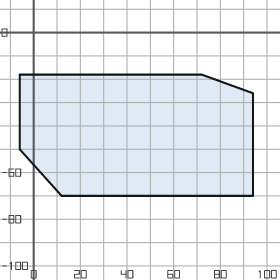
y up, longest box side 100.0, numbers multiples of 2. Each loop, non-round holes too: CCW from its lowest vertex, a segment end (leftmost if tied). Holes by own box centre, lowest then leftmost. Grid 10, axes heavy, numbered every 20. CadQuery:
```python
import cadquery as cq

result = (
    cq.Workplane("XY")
    .moveTo(12.0, -70.0)
    .lineTo(94.0, -70.0)
    .lineTo(94.0, -26.0)
    .lineTo(72.0, -18.0)
    .lineTo(-6.0, -18.0)
    .lineTo(-6.0, -50.0)
    .close()
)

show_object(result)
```